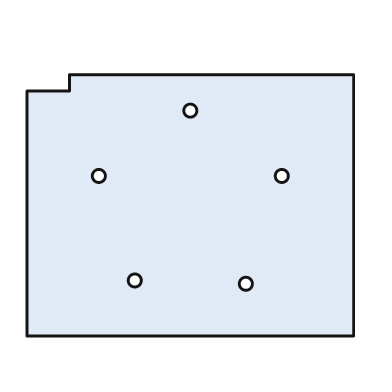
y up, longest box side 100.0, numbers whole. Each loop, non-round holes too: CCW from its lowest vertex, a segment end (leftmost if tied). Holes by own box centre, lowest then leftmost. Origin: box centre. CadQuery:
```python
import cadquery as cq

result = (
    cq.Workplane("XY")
    .moveTo(-50.0, -40.0)
    .lineTo(50.0, -40.0)
    .lineTo(50.0, 40.0)
    .lineTo(-37.0, 40.0)
    .lineTo(-37.0, 35.0)
    .lineTo(-50.0, 35.0)
    .close()
    .moveTo(17.0, -24.0)
    .circle(2.0)
    .moveTo(-17.0, -23.0)
    .circle(2.0)
    .moveTo(-28.0, 9.0)
    .circle(2.0)
    .moveTo(28.0, 9.0)
    .circle(2.0)
    .moveTo(0.0, 29.0)
    .circle(2.0)
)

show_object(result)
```